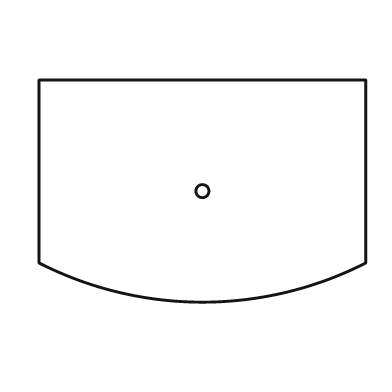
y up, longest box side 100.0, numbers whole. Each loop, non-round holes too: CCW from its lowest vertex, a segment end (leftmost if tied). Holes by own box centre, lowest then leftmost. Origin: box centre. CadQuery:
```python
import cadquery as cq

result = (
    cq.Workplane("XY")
    .moveTo(-50.0, -22.0)
    .threePointArc((0.0, -34.0), (50.0, -22.0))
    .lineTo(50.0, 34.0)
    .lineTo(-50.0, 34.0)
    .close()
    .moveTo(0.0, 0.0)
    .circle(2.0)
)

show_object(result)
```